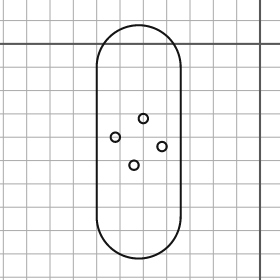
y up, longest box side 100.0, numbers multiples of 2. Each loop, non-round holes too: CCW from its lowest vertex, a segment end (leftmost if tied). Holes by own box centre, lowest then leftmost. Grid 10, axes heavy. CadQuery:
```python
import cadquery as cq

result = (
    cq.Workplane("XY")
    .moveTo(-70.0, -74.0)
    .threePointArc((-52.0, -92.0), (-34.0, -74.0))
    .lineTo(-34.0, -10.0)
    .threePointArc((-52.0, 8.0), (-70.0, -10.0))
    .close()
    .moveTo(-54.0, -52.0)
    .circle(2.0)
    .moveTo(-42.0, -44.0)
    .circle(2.0)
    .moveTo(-62.0, -40.0)
    .circle(2.0)
    .moveTo(-50.0, -32.0)
    .circle(2.0)
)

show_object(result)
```